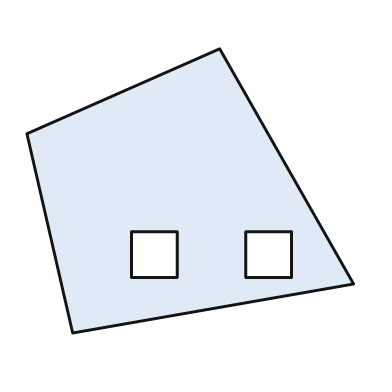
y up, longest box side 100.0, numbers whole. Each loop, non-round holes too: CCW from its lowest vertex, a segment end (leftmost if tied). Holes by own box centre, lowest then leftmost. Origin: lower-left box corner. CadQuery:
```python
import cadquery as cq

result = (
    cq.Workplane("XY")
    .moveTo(14.0, 0.0)
    .lineTo(100.0, 15.0)
    .lineTo(59.0, 87.0)
    .lineTo(0.0, 61.0)
    .close()
    .moveTo(32.0, 17.0)
    .lineTo(46.0, 17.0)
    .lineTo(46.0, 31.0)
    .lineTo(32.0, 31.0)
    .close()
    .moveTo(67.0, 17.0)
    .lineTo(81.0, 17.0)
    .lineTo(81.0, 31.0)
    .lineTo(67.0, 31.0)
    .close()
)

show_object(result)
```